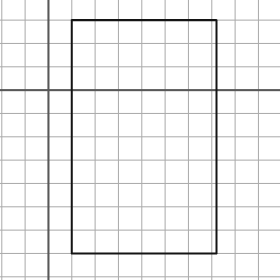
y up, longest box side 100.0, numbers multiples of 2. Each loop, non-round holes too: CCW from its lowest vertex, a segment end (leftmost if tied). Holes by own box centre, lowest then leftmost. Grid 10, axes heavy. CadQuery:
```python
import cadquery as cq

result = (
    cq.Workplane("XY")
    .moveTo(10.0, -70.0)
    .lineTo(72.0, -70.0)
    .lineTo(72.0, 30.0)
    .lineTo(10.0, 30.0)
    .close()
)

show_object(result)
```